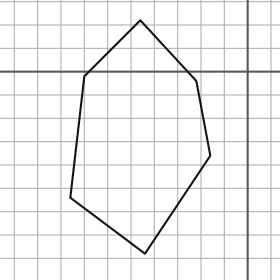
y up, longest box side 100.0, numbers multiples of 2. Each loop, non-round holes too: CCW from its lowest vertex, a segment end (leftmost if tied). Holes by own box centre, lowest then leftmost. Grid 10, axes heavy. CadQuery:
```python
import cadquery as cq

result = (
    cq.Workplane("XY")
    .moveTo(-44.0, -78.0)
    .lineTo(-16.0, -36.0)
    .lineTo(-22.0, -4.0)
    .lineTo(-46.0, 22.0)
    .lineTo(-70.0, -2.0)
    .lineTo(-76.0, -54.0)
    .close()
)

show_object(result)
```